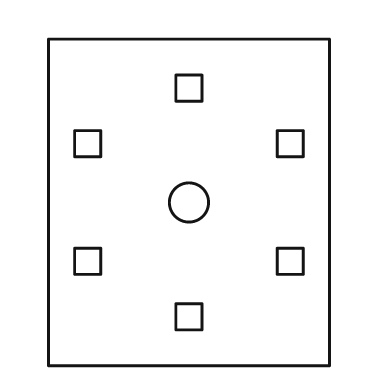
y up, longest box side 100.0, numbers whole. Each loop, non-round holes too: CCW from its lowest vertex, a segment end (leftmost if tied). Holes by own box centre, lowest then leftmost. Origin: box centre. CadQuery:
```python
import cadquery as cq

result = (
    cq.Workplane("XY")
    .moveTo(-43.0, -50.0)
    .lineTo(43.0, -50.0)
    .lineTo(43.0, 50.0)
    .lineTo(-43.0, 50.0)
    .close()
    .moveTo(-4.0, -39.0)
    .lineTo(4.0, -39.0)
    .lineTo(4.0, -31.0)
    .lineTo(-4.0, -31.0)
    .close()
    .moveTo(-35.0, -22.0)
    .lineTo(-27.0, -22.0)
    .lineTo(-27.0, -14.0)
    .lineTo(-35.0, -14.0)
    .close()
    .moveTo(27.0, -22.0)
    .lineTo(35.0, -22.0)
    .lineTo(35.0, -14.0)
    .lineTo(27.0, -14.0)
    .close()
    .moveTo(0.0, 0.0)
    .circle(6.0)
    .moveTo(-35.0, 14.0)
    .lineTo(-27.0, 14.0)
    .lineTo(-27.0, 22.0)
    .lineTo(-35.0, 22.0)
    .close()
    .moveTo(27.0, 14.0)
    .lineTo(35.0, 14.0)
    .lineTo(35.0, 22.0)
    .lineTo(27.0, 22.0)
    .close()
    .moveTo(-4.0, 31.0)
    .lineTo(4.0, 31.0)
    .lineTo(4.0, 39.0)
    .lineTo(-4.0, 39.0)
    .close()
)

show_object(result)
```